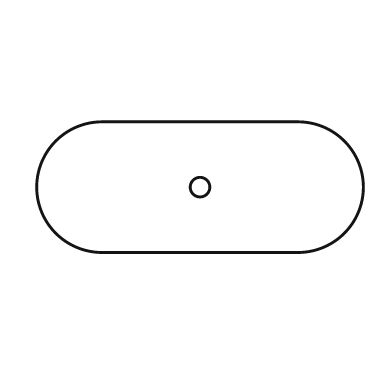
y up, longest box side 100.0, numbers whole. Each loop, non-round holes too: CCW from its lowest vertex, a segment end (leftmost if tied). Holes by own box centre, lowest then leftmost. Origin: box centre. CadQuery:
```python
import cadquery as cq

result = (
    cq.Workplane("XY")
    .moveTo(-30.0, -20.0)
    .lineTo(30.0, -20.0)
    .threePointArc((50.0, 0.0), (30.0, 20.0))
    .lineTo(-30.0, 20.0)
    .threePointArc((-50.0, 0.0), (-30.0, -20.0))
    .close()
    .moveTo(0.0, 0.0)
    .circle(3.0)
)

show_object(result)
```